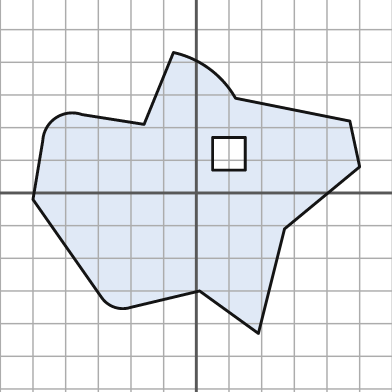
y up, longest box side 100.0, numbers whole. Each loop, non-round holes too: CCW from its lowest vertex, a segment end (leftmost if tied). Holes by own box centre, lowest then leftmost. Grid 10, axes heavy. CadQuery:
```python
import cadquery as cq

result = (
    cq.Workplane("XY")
    .moveTo(19.0, -43.0)
    .lineTo(27.0, -11.0)
    .lineTo(50.0, 8.0)
    .lineTo(47.0, 22.0)
    .lineTo(12.0, 29.0)
    .threePointArc((4.0, 38.0), (-7.0, 43.0))
    .lineTo(-16.0, 21.0)
    .lineTo(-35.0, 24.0)
    .threePointArc((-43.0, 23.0), (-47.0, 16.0))
    .lineTo(-50.0, -2.0)
    .lineTo(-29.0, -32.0)
    .threePointArc((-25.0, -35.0), (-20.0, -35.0))
    .lineTo(1.0, -30.0)
    .close()
    .moveTo(5.0, 7.0)
    .lineTo(15.0, 7.0)
    .lineTo(15.0, 17.0)
    .lineTo(5.0, 17.0)
    .close()
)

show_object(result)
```